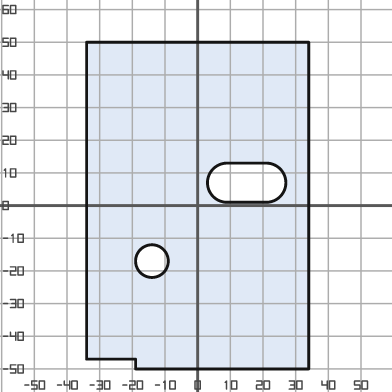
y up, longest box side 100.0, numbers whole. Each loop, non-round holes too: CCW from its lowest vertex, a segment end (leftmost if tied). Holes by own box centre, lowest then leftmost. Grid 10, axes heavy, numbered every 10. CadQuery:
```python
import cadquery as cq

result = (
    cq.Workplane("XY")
    .moveTo(-19.0, -50.0)
    .lineTo(34.0, -50.0)
    .lineTo(34.0, 50.0)
    .lineTo(-34.0, 50.0)
    .lineTo(-34.0, -47.0)
    .lineTo(-19.0, -47.0)
    .close()
    .moveTo(-14.0, -17.0)
    .circle(5.0)
    .moveTo(9.0, 1.0)
    .lineTo(21.0, 1.0)
    .threePointArc((27.0, 7.0), (21.0, 13.0))
    .lineTo(9.0, 13.0)
    .threePointArc((3.0, 7.0), (9.0, 1.0))
    .close()
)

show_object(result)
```